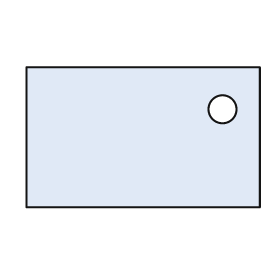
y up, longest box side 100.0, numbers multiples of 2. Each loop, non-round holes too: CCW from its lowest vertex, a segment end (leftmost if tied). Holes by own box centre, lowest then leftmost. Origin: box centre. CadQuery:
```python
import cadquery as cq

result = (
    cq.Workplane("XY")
    .moveTo(-50.0, -30.0)
    .lineTo(50.0, -30.0)
    .lineTo(50.0, 30.0)
    .lineTo(-50.0, 30.0)
    .close()
    .moveTo(34.0, 12.0)
    .circle(6.0)
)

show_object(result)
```